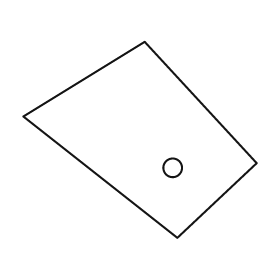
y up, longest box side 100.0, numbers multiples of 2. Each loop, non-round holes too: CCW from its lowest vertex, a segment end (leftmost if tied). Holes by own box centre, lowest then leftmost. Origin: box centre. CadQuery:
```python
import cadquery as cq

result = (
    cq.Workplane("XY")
    .moveTo(16.0, -42.0)
    .lineTo(50.0, -10.0)
    .lineTo(2.0, 42.0)
    .lineTo(-50.0, 10.0)
    .close()
    .moveTo(14.0, -12.0)
    .circle(4.0)
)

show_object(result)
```